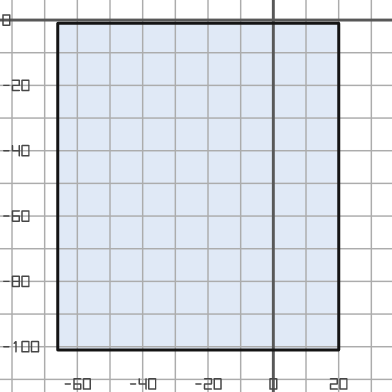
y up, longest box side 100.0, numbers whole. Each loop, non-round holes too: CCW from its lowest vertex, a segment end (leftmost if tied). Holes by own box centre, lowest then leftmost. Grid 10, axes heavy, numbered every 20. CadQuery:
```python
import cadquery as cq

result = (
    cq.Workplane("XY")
    .moveTo(-66.0, -101.0)
    .lineTo(20.0, -101.0)
    .lineTo(20.0, -1.0)
    .lineTo(-66.0, -1.0)
    .close()
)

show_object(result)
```